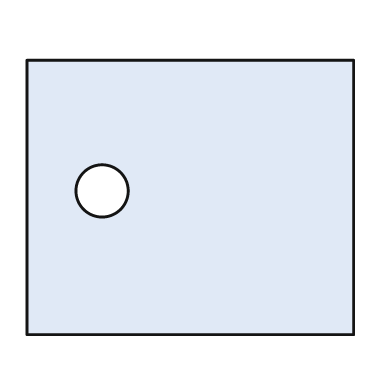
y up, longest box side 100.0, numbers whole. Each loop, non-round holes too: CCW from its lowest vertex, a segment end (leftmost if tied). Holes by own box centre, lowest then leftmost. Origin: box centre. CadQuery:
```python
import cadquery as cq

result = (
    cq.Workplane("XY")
    .moveTo(-50.0, -42.0)
    .lineTo(50.0, -42.0)
    .lineTo(50.0, 42.0)
    .lineTo(-50.0, 42.0)
    .close()
    .moveTo(-27.0, 2.0)
    .circle(8.0)
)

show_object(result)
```